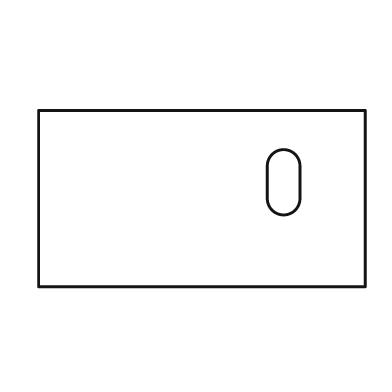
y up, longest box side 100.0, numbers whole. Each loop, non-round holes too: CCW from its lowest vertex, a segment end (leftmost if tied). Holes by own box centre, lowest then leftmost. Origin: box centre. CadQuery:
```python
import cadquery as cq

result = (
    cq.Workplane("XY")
    .moveTo(-50.0, -27.0)
    .lineTo(50.0, -27.0)
    .lineTo(50.0, 27.0)
    .lineTo(-50.0, 27.0)
    .close()
    .moveTo(20.0, 0.0)
    .threePointArc((25.0, -5.0), (30.0, 0.0))
    .lineTo(30.0, 10.0)
    .threePointArc((25.0, 15.0), (20.0, 10.0))
    .close()
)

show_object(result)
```